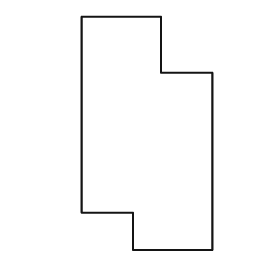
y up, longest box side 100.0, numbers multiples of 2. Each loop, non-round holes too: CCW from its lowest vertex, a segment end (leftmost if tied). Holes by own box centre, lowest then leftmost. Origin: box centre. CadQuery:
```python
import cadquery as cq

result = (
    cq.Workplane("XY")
    .moveTo(-6.0, -50.0)
    .lineTo(28.0, -50.0)
    .lineTo(28.0, 26.0)
    .lineTo(6.0, 26.0)
    .lineTo(6.0, 50.0)
    .lineTo(-28.0, 50.0)
    .lineTo(-28.0, -34.0)
    .lineTo(-6.0, -34.0)
    .close()
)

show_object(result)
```